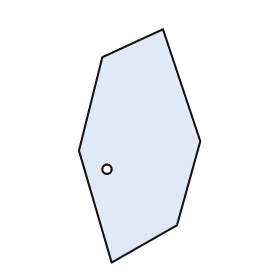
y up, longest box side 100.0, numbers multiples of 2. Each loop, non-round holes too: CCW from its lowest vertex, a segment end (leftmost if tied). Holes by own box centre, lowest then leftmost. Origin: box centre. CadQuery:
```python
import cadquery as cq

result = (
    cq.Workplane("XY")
    .moveTo(-12.0, -50.0)
    .lineTo(16.0, -34.0)
    .lineTo(26.0, 2.0)
    .lineTo(10.0, 50.0)
    .lineTo(-16.0, 38.0)
    .lineTo(-26.0, -2.0)
    .close()
    .moveTo(-14.0, -10.0)
    .circle(2.0)
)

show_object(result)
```